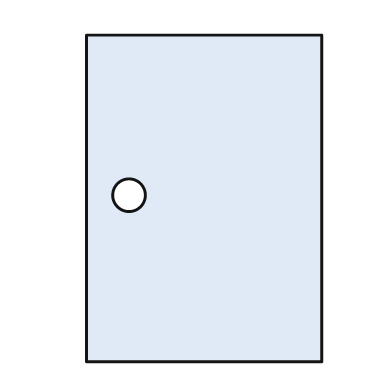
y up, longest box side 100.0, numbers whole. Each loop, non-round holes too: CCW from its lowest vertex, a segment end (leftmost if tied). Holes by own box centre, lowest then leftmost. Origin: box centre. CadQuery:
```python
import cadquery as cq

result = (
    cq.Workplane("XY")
    .moveTo(-36.0, -50.0)
    .lineTo(36.0, -50.0)
    .lineTo(36.0, 50.0)
    .lineTo(-36.0, 50.0)
    .close()
    .moveTo(-23.0, 1.0)
    .circle(5.0)
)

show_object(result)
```